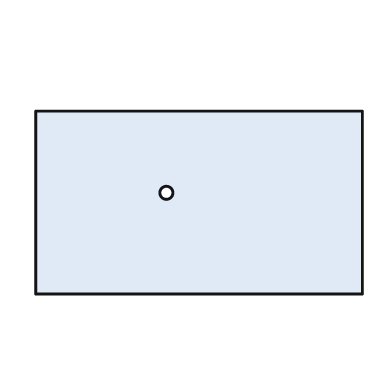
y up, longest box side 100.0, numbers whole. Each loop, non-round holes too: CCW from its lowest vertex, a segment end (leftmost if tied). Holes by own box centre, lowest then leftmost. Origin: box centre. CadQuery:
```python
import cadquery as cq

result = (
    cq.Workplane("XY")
    .moveTo(-50.0, -28.0)
    .lineTo(50.0, -28.0)
    .lineTo(50.0, 28.0)
    .lineTo(-50.0, 28.0)
    .close()
    .moveTo(-10.0, 3.0)
    .circle(2.0)
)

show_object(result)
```